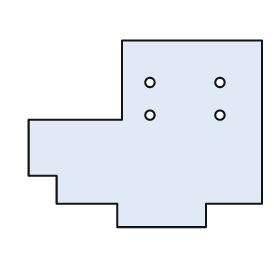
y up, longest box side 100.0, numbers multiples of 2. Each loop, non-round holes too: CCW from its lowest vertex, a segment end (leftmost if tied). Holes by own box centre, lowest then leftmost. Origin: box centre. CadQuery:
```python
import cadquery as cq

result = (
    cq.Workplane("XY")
    .moveTo(-12.0, -40.0)
    .lineTo(26.0, -40.0)
    .lineTo(26.0, -30.0)
    .lineTo(50.0, -30.0)
    .lineTo(50.0, 40.0)
    .lineTo(-10.0, 40.0)
    .lineTo(-10.0, 6.0)
    .lineTo(-50.0, 6.0)
    .lineTo(-50.0, -18.0)
    .lineTo(-38.0, -18.0)
    .lineTo(-38.0, -30.0)
    .lineTo(-12.0, -30.0)
    .close()
    .moveTo(2.0, 8.0)
    .circle(2.0)
    .moveTo(32.0, 8.0)
    .circle(2.0)
    .moveTo(2.0, 22.0)
    .circle(2.0)
    .moveTo(32.0, 22.0)
    .circle(2.0)
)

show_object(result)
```